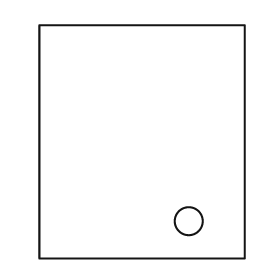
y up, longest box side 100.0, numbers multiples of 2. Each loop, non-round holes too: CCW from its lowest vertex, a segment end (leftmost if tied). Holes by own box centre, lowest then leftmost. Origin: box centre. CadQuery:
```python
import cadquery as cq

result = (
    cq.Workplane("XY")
    .moveTo(-44.0, -50.0)
    .lineTo(44.0, -50.0)
    .lineTo(44.0, 50.0)
    .lineTo(-44.0, 50.0)
    .close()
    .moveTo(20.0, -34.0)
    .circle(6.0)
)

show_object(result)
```